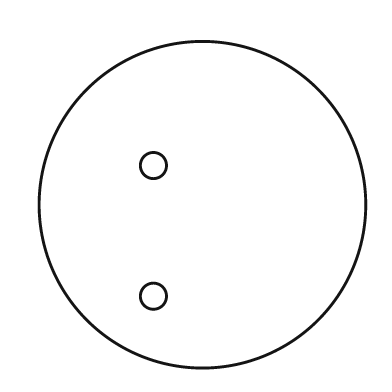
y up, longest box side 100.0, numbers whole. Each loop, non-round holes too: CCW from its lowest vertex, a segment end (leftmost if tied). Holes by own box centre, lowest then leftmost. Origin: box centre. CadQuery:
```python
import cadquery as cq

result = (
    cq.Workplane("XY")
    .moveTo(0.0, 0.0)
    .circle(50.0)
    .moveTo(-15.0, -28.0)
    .circle(4.0)
    .moveTo(-15.0, 12.0)
    .circle(4.0)
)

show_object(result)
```